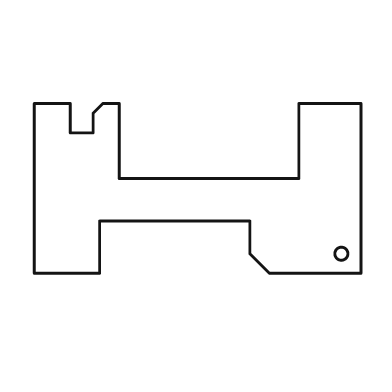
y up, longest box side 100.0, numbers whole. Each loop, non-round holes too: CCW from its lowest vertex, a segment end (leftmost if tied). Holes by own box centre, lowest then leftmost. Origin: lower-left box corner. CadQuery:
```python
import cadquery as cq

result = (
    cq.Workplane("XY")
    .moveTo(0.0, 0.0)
    .lineTo(20.0, 0.0)
    .lineTo(20.0, 16.0)
    .lineTo(66.0, 16.0)
    .lineTo(66.0, 6.0)
    .lineTo(72.0, 0.0)
    .lineTo(100.0, 0.0)
    .lineTo(100.0, 52.0)
    .lineTo(81.0, 52.0)
    .lineTo(81.0, 29.0)
    .lineTo(26.0, 29.0)
    .lineTo(26.0, 52.0)
    .lineTo(21.0, 52.0)
    .lineTo(18.0, 49.0)
    .lineTo(18.0, 43.0)
    .lineTo(11.0, 43.0)
    .lineTo(11.0, 52.0)
    .lineTo(0.0, 52.0)
    .close()
    .moveTo(94.0, 6.0)
    .circle(2.0)
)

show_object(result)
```